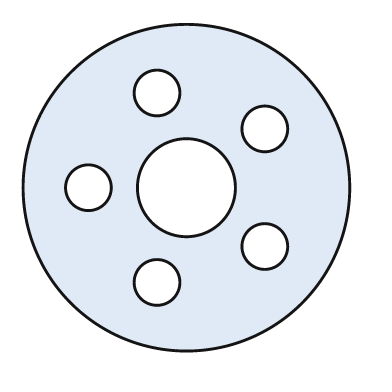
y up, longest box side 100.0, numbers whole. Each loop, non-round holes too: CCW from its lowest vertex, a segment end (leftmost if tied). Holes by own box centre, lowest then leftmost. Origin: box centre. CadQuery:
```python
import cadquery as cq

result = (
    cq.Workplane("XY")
    .moveTo(0.0, 0.0)
    .circle(50.0)
    .moveTo(-9.0, -29.0)
    .circle(7.0)
    .moveTo(24.0, -18.0)
    .circle(7.0)
    .moveTo(-30.0, 0.0)
    .circle(7.0)
    .moveTo(0.0, 0.0)
    .circle(15.0)
    .moveTo(24.0, 18.0)
    .circle(7.0)
    .moveTo(-9.0, 29.0)
    .circle(7.0)
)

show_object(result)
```